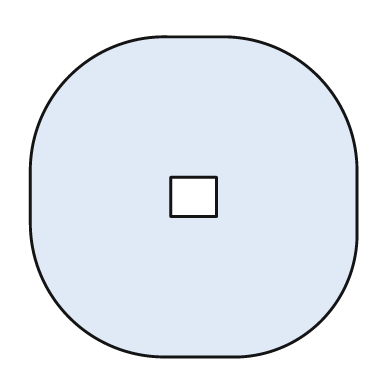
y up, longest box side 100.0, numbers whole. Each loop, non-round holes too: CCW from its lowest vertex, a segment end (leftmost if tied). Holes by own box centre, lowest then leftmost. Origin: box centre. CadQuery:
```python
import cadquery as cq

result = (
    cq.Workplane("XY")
    .moveTo(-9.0, -49.0)
    .lineTo(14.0, -49.0)
    .threePointArc((39.0, -38.0), (50.0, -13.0))
    .lineTo(50.0, 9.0)
    .threePointArc((38.0, 37.0), (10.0, 49.0))
    .lineTo(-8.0, 49.0)
    .threePointArc((-38.0, 37.0), (-50.0, 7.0))
    .lineTo(-50.0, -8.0)
    .threePointArc((-38.0, -37.0), (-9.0, -49.0))
    .close()
    .moveTo(-7.0, -6.0)
    .lineTo(7.0, -6.0)
    .lineTo(7.0, 6.0)
    .lineTo(-7.0, 6.0)
    .close()
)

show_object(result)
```